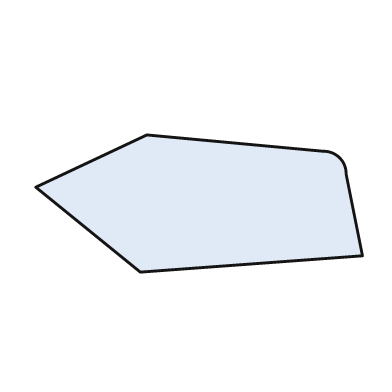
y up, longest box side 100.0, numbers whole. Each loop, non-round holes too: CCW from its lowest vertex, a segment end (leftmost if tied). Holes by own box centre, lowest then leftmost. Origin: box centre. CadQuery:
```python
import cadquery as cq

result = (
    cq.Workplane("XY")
    .moveTo(-18.0, -21.0)
    .lineTo(50.0, -16.0)
    .lineTo(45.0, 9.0)
    .threePointArc((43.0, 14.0), (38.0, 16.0))
    .lineTo(-16.0, 21.0)
    .lineTo(-50.0, 5.0)
    .close()
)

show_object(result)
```